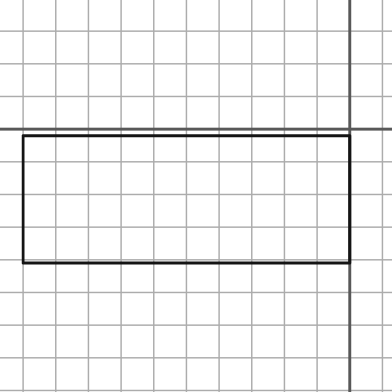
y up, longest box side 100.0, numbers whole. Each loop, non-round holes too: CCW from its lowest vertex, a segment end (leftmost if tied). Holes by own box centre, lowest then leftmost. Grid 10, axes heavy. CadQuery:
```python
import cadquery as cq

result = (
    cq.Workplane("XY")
    .moveTo(-100.0, -41.0)
    .lineTo(0.0, -41.0)
    .lineTo(0.0, -2.0)
    .lineTo(-100.0, -2.0)
    .close()
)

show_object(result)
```